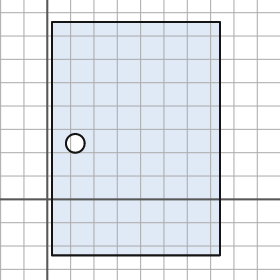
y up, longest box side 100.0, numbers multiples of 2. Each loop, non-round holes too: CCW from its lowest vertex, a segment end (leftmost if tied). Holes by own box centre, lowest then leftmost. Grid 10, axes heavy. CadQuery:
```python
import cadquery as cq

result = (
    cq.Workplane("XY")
    .moveTo(2.0, -24.0)
    .lineTo(74.0, -24.0)
    .lineTo(74.0, 76.0)
    .lineTo(2.0, 76.0)
    .close()
    .moveTo(12.0, 24.0)
    .circle(4.0)
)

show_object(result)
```